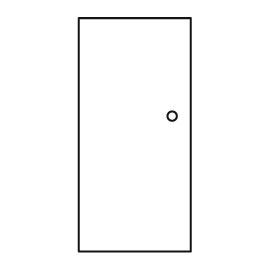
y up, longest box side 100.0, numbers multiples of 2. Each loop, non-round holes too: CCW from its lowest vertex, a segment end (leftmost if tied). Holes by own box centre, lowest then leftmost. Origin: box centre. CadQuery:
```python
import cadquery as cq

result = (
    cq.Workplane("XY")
    .moveTo(-24.0, -50.0)
    .lineTo(24.0, -50.0)
    .lineTo(24.0, 50.0)
    .lineTo(-24.0, 50.0)
    .close()
    .moveTo(16.0, 8.0)
    .circle(2.0)
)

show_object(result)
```